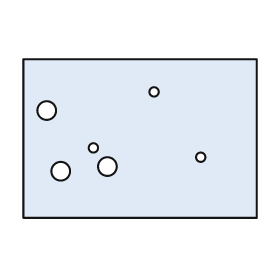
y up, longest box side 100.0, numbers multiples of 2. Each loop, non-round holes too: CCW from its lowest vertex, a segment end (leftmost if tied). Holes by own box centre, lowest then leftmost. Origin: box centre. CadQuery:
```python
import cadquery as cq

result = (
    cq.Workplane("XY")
    .moveTo(-50.0, -34.0)
    .lineTo(50.0, -34.0)
    .lineTo(50.0, 34.0)
    .lineTo(-50.0, 34.0)
    .close()
    .moveTo(-34.0, -14.0)
    .circle(4.0)
    .moveTo(-14.0, -12.0)
    .circle(4.0)
    .moveTo(26.0, -8.0)
    .circle(2.0)
    .moveTo(-20.0, -4.0)
    .circle(2.0)
    .moveTo(-40.0, 12.0)
    .circle(4.0)
    .moveTo(6.0, 20.0)
    .circle(2.0)
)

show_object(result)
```